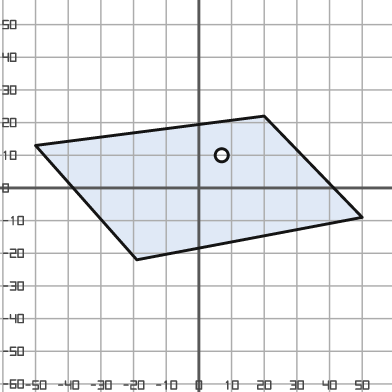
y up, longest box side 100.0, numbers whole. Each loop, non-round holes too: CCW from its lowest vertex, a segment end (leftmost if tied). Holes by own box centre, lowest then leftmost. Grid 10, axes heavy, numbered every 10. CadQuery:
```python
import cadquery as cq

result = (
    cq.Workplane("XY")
    .moveTo(-19.0, -22.0)
    .lineTo(50.0, -9.0)
    .lineTo(20.0, 22.0)
    .lineTo(-50.0, 13.0)
    .close()
    .moveTo(7.0, 10.0)
    .circle(2.0)
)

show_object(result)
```